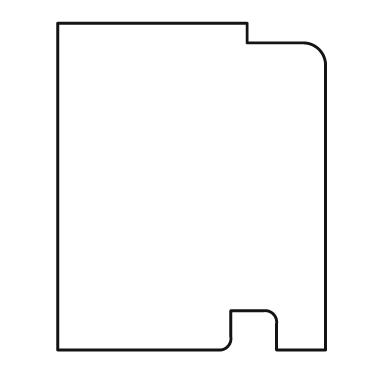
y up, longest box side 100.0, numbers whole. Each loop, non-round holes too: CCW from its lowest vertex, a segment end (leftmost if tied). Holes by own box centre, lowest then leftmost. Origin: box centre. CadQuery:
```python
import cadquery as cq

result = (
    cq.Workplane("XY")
    .moveTo(-41.0, -50.0)
    .lineTo(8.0, -50.0)
    .threePointArc((11.0, -49.0), (12.0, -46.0))
    .lineTo(12.0, -38.0)
    .lineTo(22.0, -38.0)
    .threePointArc((25.0, -39.0), (26.0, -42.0))
    .lineTo(26.0, -50.0)
    .lineTo(41.0, -50.0)
    .lineTo(41.0, 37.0)
    .threePointArc((39.0, 42.0), (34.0, 44.0))
    .lineTo(17.0, 44.0)
    .lineTo(17.0, 50.0)
    .lineTo(-41.0, 50.0)
    .close()
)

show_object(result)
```